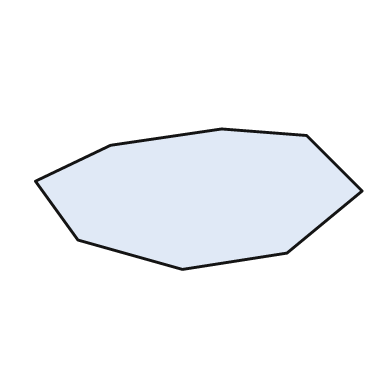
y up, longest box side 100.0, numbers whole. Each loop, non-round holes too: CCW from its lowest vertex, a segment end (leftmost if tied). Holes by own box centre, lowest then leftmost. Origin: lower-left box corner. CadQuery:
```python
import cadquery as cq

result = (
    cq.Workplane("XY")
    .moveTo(45.0, 0.0)
    .lineTo(77.0, 5.0)
    .lineTo(100.0, 24.0)
    .lineTo(83.0, 41.0)
    .lineTo(57.0, 43.0)
    .lineTo(23.0, 38.0)
    .lineTo(0.0, 27.0)
    .lineTo(13.0, 9.0)
    .close()
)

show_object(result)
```